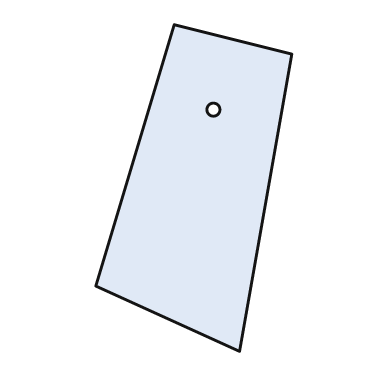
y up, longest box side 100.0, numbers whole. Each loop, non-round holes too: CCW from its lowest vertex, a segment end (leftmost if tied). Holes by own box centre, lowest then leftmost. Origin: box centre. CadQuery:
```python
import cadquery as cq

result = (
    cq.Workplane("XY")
    .moveTo(14.0, -50.0)
    .lineTo(30.0, 41.0)
    .lineTo(-6.0, 50.0)
    .lineTo(-30.0, -30.0)
    .close()
    .moveTo(6.0, 24.0)
    .circle(2.0)
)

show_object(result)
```